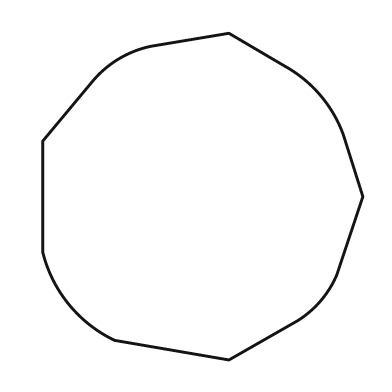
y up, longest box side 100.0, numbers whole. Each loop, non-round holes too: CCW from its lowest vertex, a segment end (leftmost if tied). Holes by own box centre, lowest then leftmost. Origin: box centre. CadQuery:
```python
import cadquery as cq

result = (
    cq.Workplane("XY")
    .moveTo(8.0, -50.0)
    .lineTo(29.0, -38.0)
    .threePointArc((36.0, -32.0), (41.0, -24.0))
    .lineTo(49.0, 0.0)
    .lineTo(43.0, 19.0)
    .threePointArc((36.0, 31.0), (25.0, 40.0))
    .lineTo(8.0, 50.0)
    .lineTo(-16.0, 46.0)
    .threePointArc((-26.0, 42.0), (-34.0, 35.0))
    .lineTo(-49.0, 17.0)
    .lineTo(-49.0, -17.0)
    .threePointArc((-41.0, -33.0), (-27.0, -44.0))
    .close()
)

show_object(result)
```